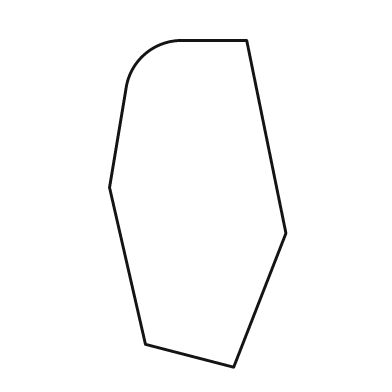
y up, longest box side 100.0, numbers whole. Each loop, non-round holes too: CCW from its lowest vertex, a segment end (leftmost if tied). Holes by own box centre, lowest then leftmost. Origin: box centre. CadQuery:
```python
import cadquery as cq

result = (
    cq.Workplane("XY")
    .moveTo(11.0, -50.0)
    .lineTo(27.0, -9.0)
    .lineTo(15.0, 50.0)
    .lineTo(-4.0, 50.0)
    .threePointArc((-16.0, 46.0), (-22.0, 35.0))
    .lineTo(-27.0, 5.0)
    .lineTo(-16.0, -43.0)
    .close()
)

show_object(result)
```